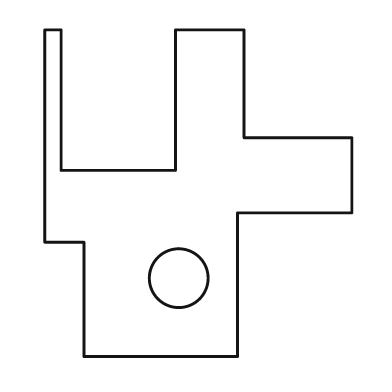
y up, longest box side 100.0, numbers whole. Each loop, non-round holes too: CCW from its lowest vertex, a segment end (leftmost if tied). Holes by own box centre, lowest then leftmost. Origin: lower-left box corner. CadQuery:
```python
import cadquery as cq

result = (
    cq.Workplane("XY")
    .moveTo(12.0, 0.0)
    .lineTo(59.0, 0.0)
    .lineTo(59.0, 44.0)
    .lineTo(94.0, 44.0)
    .lineTo(94.0, 67.0)
    .lineTo(61.0, 67.0)
    .lineTo(61.0, 100.0)
    .lineTo(40.0, 100.0)
    .lineTo(40.0, 57.0)
    .lineTo(5.0, 57.0)
    .lineTo(5.0, 100.0)
    .lineTo(0.0, 100.0)
    .lineTo(0.0, 35.0)
    .lineTo(12.0, 35.0)
    .close()
    .moveTo(41.0, 24.0)
    .circle(9.0)
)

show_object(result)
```